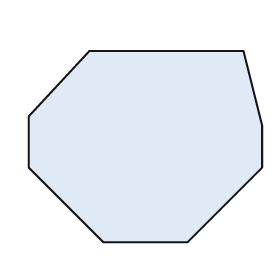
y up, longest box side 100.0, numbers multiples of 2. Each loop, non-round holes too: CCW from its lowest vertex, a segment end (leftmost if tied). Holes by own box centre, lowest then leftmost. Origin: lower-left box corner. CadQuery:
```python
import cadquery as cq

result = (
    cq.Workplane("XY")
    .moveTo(32.0, 0.0)
    .lineTo(68.0, 0.0)
    .lineTo(100.0, 32.0)
    .lineTo(100.0, 50.0)
    .lineTo(92.0, 82.0)
    .lineTo(26.0, 82.0)
    .lineTo(0.0, 54.0)
    .lineTo(0.0, 32.0)
    .close()
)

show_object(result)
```